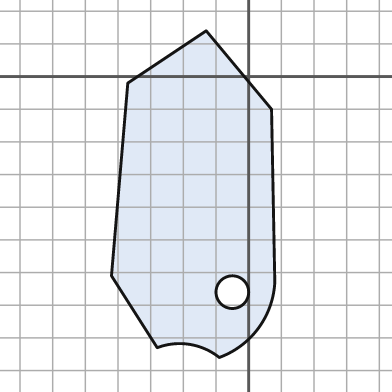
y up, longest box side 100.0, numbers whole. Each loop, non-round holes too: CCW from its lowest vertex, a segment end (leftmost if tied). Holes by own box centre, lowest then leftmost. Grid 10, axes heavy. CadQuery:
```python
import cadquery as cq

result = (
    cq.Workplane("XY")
    .moveTo(-9.0, -86.0)
    .threePointArc((3.0, -77.0), (8.0, -63.0))
    .lineTo(7.0, -10.0)
    .lineTo(-13.0, 14.0)
    .lineTo(-37.0, -2.0)
    .lineTo(-42.0, -61.0)
    .lineTo(-28.0, -83.0)
    .threePointArc((-18.0, -82.0), (-9.0, -86.0))
    .close()
    .moveTo(-5.0, -66.0)
    .circle(5.0)
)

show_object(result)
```